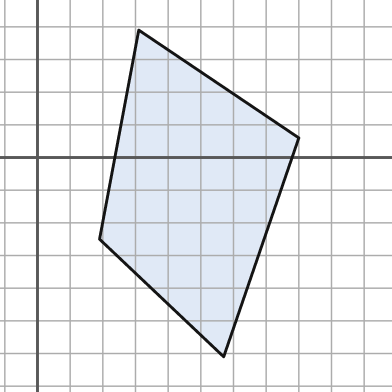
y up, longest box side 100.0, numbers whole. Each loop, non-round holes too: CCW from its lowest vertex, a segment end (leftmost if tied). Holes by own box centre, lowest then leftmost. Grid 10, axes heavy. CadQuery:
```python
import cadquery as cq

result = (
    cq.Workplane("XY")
    .moveTo(57.0, -61.0)
    .lineTo(80.0, 6.0)
    .lineTo(31.0, 39.0)
    .lineTo(19.0, -25.0)
    .close()
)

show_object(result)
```